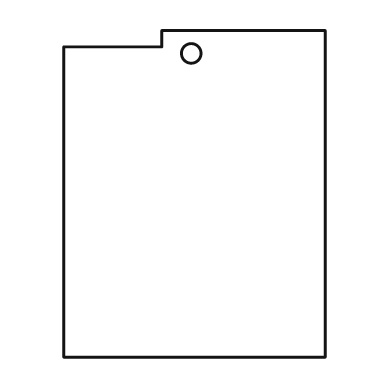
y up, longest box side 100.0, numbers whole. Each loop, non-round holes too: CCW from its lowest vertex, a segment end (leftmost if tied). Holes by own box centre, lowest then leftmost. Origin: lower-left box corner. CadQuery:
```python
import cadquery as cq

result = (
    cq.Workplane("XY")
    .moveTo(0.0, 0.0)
    .lineTo(80.0, 0.0)
    .lineTo(80.0, 100.0)
    .lineTo(30.0, 100.0)
    .lineTo(30.0, 95.0)
    .lineTo(0.0, 95.0)
    .close()
    .moveTo(39.0, 93.0)
    .circle(3.0)
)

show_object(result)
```